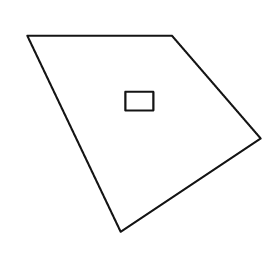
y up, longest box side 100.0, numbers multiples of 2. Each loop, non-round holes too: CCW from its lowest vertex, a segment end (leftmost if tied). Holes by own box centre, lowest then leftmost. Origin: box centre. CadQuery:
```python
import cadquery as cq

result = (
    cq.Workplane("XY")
    .moveTo(-10.0, -42.0)
    .lineTo(50.0, -2.0)
    .lineTo(12.0, 42.0)
    .lineTo(-50.0, 42.0)
    .close()
    .moveTo(-8.0, 10.0)
    .lineTo(4.0, 10.0)
    .lineTo(4.0, 18.0)
    .lineTo(-8.0, 18.0)
    .close()
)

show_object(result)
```